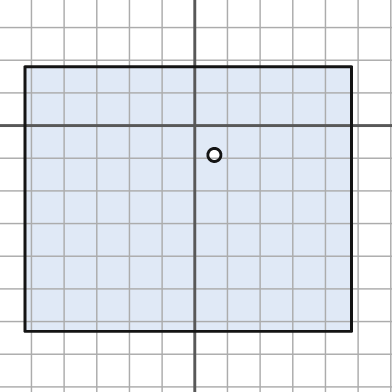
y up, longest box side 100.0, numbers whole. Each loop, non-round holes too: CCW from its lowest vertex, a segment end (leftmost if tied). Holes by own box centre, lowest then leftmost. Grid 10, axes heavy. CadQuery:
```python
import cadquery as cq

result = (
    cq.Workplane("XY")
    .moveTo(-52.0, -63.0)
    .lineTo(48.0, -63.0)
    .lineTo(48.0, 18.0)
    .lineTo(-52.0, 18.0)
    .close()
    .moveTo(6.0, -9.0)
    .circle(2.0)
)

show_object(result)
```